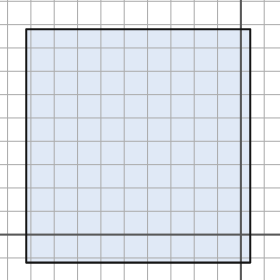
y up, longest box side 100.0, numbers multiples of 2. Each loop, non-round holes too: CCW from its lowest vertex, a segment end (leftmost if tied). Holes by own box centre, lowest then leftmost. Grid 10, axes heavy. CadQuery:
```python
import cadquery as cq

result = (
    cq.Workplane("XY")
    .moveTo(-92.0, -12.0)
    .lineTo(4.0, -12.0)
    .lineTo(4.0, 88.0)
    .lineTo(-92.0, 88.0)
    .close()
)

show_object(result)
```